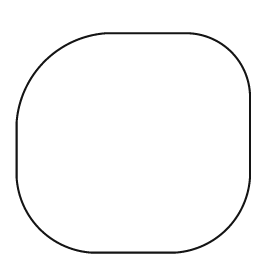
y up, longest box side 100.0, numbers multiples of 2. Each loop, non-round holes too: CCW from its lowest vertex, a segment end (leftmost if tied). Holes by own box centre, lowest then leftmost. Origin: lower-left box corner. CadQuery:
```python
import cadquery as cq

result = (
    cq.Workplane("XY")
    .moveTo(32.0, 0.0)
    .lineTo(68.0, 0.0)
    .threePointArc((90.0, 10.0), (100.0, 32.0))
    .lineTo(100.0, 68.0)
    .threePointArc((92.0, 86.0), (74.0, 94.0))
    .lineTo(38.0, 94.0)
    .threePointArc((12.0, 82.0), (0.0, 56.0))
    .lineTo(0.0, 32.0)
    .threePointArc((10.0, 10.0), (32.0, 0.0))
    .close()
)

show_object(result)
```